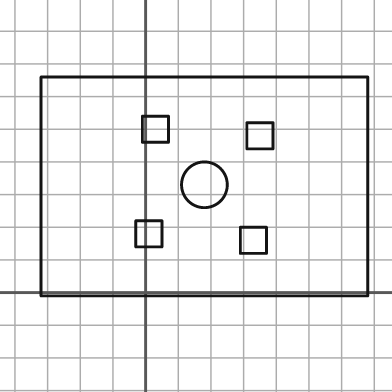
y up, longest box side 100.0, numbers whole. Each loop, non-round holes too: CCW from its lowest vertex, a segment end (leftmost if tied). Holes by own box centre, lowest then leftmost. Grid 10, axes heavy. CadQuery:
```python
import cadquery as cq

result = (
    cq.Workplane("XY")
    .moveTo(-32.0, -1.0)
    .lineTo(68.0, -1.0)
    .lineTo(68.0, 66.0)
    .lineTo(-32.0, 66.0)
    .close()
    .moveTo(29.0, 12.0)
    .lineTo(37.0, 12.0)
    .lineTo(37.0, 20.0)
    .lineTo(29.0, 20.0)
    .close()
    .moveTo(-3.0, 14.0)
    .lineTo(5.0, 14.0)
    .lineTo(5.0, 22.0)
    .lineTo(-3.0, 22.0)
    .close()
    .moveTo(18.0, 33.0)
    .circle(7.0)
    .moveTo(31.0, 44.0)
    .lineTo(39.0, 44.0)
    .lineTo(39.0, 52.0)
    .lineTo(31.0, 52.0)
    .close()
    .moveTo(-1.0, 46.0)
    .lineTo(7.0, 46.0)
    .lineTo(7.0, 54.0)
    .lineTo(-1.0, 54.0)
    .close()
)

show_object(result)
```